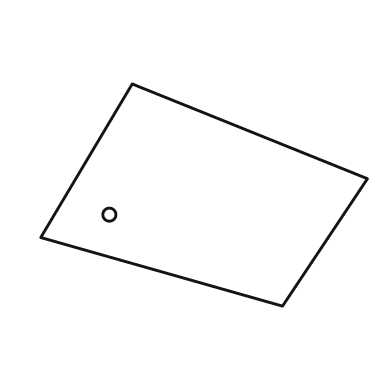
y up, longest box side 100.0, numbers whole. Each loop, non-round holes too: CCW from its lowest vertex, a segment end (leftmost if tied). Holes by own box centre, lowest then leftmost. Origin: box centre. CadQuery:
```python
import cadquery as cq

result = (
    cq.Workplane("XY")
    .moveTo(24.0, -34.0)
    .lineTo(50.0, 5.0)
    .lineTo(-22.0, 34.0)
    .lineTo(-50.0, -13.0)
    .close()
    .moveTo(-29.0, -6.0)
    .circle(2.0)
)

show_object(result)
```